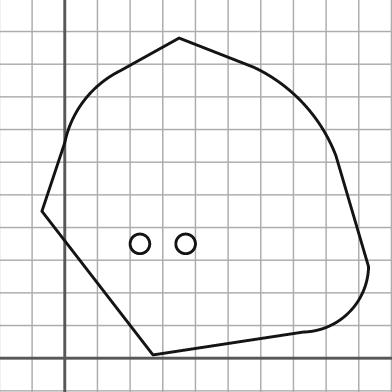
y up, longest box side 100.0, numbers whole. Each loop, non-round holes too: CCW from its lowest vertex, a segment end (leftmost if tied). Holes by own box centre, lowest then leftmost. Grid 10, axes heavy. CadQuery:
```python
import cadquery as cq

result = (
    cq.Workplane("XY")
    .moveTo(27.0, 1.0)
    .lineTo(73.0, 8.0)
    .threePointArc((87.0, 14.0), (93.0, 28.0))
    .lineTo(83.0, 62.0)
    .threePointArc((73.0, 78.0), (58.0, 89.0))
    .lineTo(35.0, 98.0)
    .lineTo(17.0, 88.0)
    .threePointArc((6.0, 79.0), (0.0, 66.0))
    .lineTo(-7.0, 45.0)
    .close()
    .moveTo(23.0, 35.0)
    .circle(3.0)
    .moveTo(37.0, 35.0)
    .circle(3.0)
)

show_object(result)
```